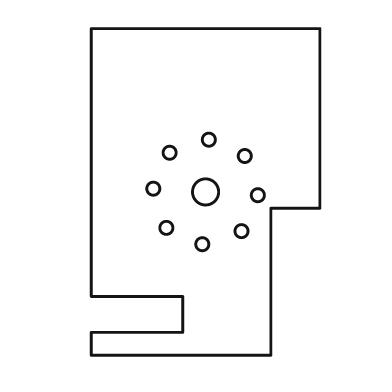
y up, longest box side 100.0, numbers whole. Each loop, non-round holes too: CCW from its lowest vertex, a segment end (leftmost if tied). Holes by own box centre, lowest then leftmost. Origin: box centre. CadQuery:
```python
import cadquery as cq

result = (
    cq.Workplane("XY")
    .moveTo(-35.0, -50.0)
    .lineTo(20.0, -50.0)
    .lineTo(20.0, -5.0)
    .lineTo(35.0, -5.0)
    .lineTo(35.0, 50.0)
    .lineTo(-35.0, 50.0)
    .lineTo(-35.0, -32.0)
    .lineTo(-7.0, -32.0)
    .lineTo(-7.0, -43.0)
    .lineTo(-35.0, -43.0)
    .close()
    .moveTo(-1.0, -16.0)
    .circle(2.0)
    .moveTo(11.0, -12.0)
    .circle(2.0)
    .moveTo(-12.0, -11.0)
    .circle(2.0)
    .moveTo(16.0, -1.0)
    .circle(2.0)
    .moveTo(0.0, 0.0)
    .circle(4.0)
    .moveTo(-16.0, 1.0)
    .circle(2.0)
    .moveTo(12.0, 11.0)
    .circle(2.0)
    .moveTo(-11.0, 12.0)
    .circle(2.0)
    .moveTo(1.0, 16.0)
    .circle(2.0)
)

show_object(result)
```